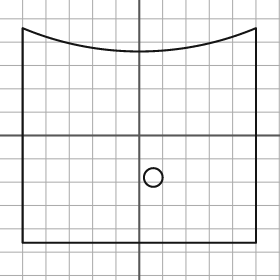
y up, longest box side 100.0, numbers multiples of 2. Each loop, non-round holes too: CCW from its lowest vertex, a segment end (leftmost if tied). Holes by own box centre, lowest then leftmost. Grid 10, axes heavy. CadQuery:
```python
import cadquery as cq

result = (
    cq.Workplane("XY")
    .moveTo(-50.0, -46.0)
    .lineTo(50.0, -46.0)
    .lineTo(50.0, 46.0)
    .threePointArc((0.0, 36.0), (-50.0, 46.0))
    .close()
    .moveTo(6.0, -18.0)
    .circle(4.0)
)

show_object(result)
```